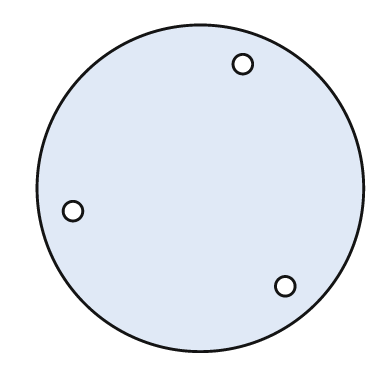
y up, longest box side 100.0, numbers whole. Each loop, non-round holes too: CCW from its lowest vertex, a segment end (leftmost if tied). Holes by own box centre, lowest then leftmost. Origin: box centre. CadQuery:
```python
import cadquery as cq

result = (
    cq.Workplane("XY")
    .moveTo(0.0, 0.0)
    .circle(50.0)
    .moveTo(26.0, -30.0)
    .circle(3.0)
    .moveTo(-39.0, -7.0)
    .circle(3.0)
    .moveTo(13.0, 38.0)
    .circle(3.0)
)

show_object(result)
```